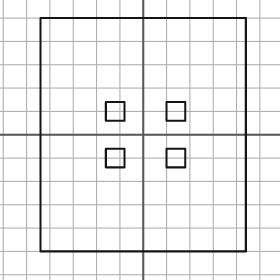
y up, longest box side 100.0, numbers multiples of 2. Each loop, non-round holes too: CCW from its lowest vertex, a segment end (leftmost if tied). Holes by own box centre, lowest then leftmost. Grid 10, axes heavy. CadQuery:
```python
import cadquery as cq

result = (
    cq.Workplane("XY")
    .moveTo(-44.0, -50.0)
    .lineTo(44.0, -50.0)
    .lineTo(44.0, 50.0)
    .lineTo(-44.0, 50.0)
    .close()
    .moveTo(-16.0, -14.0)
    .lineTo(-8.0, -14.0)
    .lineTo(-8.0, -6.0)
    .lineTo(-16.0, -6.0)
    .close()
    .moveTo(10.0, -14.0)
    .lineTo(18.0, -14.0)
    .lineTo(18.0, -6.0)
    .lineTo(10.0, -6.0)
    .close()
    .moveTo(-16.0, 6.0)
    .lineTo(-8.0, 6.0)
    .lineTo(-8.0, 14.0)
    .lineTo(-16.0, 14.0)
    .close()
    .moveTo(10.0, 6.0)
    .lineTo(18.0, 6.0)
    .lineTo(18.0, 14.0)
    .lineTo(10.0, 14.0)
    .close()
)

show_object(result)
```